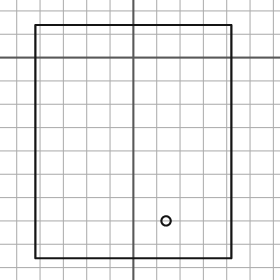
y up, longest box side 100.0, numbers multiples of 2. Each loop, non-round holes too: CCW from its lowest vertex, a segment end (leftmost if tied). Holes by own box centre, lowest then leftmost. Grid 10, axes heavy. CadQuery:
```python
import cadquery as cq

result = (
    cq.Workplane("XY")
    .moveTo(-42.0, -86.0)
    .lineTo(42.0, -86.0)
    .lineTo(42.0, 14.0)
    .lineTo(-42.0, 14.0)
    .close()
    .moveTo(14.0, -70.0)
    .circle(2.0)
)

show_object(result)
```